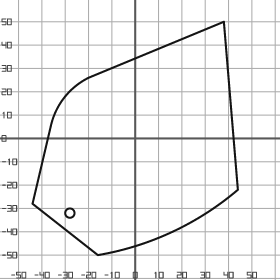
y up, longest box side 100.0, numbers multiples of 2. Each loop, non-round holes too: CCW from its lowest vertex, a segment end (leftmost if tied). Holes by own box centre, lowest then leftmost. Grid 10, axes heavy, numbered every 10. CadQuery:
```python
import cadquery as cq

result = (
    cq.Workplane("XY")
    .moveTo(-16.0, -50.0)
    .threePointArc((16.0, -40.0), (44.0, -22.0))
    .lineTo(38.0, 50.0)
    .lineTo(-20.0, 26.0)
    .threePointArc((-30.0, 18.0), (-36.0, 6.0))
    .lineTo(-44.0, -28.0)
    .close()
    .moveTo(-28.0, -32.0)
    .circle(2.0)
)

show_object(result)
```